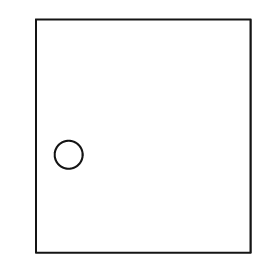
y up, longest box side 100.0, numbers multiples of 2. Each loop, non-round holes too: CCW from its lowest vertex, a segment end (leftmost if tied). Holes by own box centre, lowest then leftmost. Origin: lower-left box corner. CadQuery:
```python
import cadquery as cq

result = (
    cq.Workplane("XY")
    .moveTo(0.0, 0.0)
    .lineTo(92.0, 0.0)
    .lineTo(92.0, 100.0)
    .lineTo(0.0, 100.0)
    .close()
    .moveTo(14.0, 42.0)
    .circle(6.0)
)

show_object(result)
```